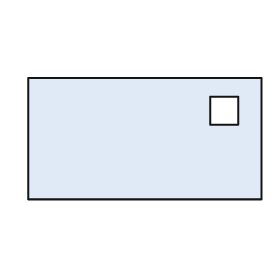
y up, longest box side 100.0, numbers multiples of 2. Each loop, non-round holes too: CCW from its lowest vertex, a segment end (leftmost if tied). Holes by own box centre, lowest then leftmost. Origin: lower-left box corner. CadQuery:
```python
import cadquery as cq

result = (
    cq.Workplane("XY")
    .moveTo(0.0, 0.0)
    .lineTo(100.0, 0.0)
    .lineTo(100.0, 52.0)
    .lineTo(0.0, 52.0)
    .close()
    .moveTo(78.0, 32.0)
    .lineTo(90.0, 32.0)
    .lineTo(90.0, 44.0)
    .lineTo(78.0, 44.0)
    .close()
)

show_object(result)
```